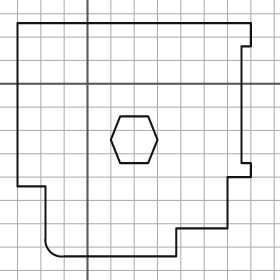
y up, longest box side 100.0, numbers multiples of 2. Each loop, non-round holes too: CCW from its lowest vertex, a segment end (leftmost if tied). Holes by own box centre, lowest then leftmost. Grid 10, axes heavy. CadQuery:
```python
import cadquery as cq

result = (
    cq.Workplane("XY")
    .moveTo(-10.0, -74.0)
    .lineTo(38.0, -74.0)
    .lineTo(38.0, -62.0)
    .lineTo(60.0, -62.0)
    .lineTo(60.0, -40.0)
    .lineTo(70.0, -40.0)
    .lineTo(70.0, -34.0)
    .lineTo(66.0, -34.0)
    .lineTo(66.0, 16.0)
    .lineTo(70.0, 16.0)
    .lineTo(70.0, 26.0)
    .lineTo(-30.0, 26.0)
    .lineTo(-30.0, -44.0)
    .lineTo(-18.0, -44.0)
    .lineTo(-18.0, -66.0)
    .threePointArc((-16.0, -72.0), (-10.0, -74.0))
    .close()
    .moveTo(14.0, -34.0)
    .lineTo(26.0, -34.0)
    .lineTo(30.0, -24.0)
    .lineTo(26.0, -14.0)
    .lineTo(14.0, -14.0)
    .lineTo(10.0, -24.0)
    .close()
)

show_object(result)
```